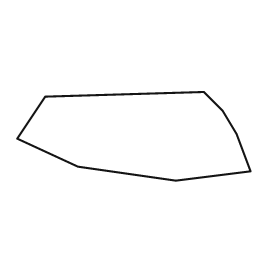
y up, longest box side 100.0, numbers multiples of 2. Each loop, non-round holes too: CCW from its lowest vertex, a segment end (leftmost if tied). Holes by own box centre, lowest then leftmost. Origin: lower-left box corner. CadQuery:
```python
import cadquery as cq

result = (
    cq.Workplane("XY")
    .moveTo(68.0, 0.0)
    .lineTo(100.0, 4.0)
    .lineTo(94.0, 20.0)
    .lineTo(88.0, 30.0)
    .lineTo(80.0, 38.0)
    .lineTo(12.0, 36.0)
    .lineTo(0.0, 18.0)
    .lineTo(26.0, 6.0)
    .close()
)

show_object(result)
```